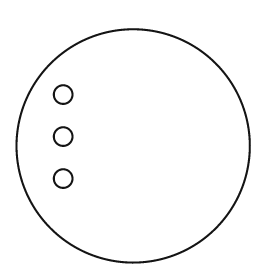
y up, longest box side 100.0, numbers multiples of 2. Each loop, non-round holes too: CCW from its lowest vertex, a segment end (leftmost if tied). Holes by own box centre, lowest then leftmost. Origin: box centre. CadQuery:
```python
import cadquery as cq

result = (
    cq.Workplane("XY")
    .moveTo(0.0, 0.0)
    .circle(50.0)
    .moveTo(-30.0, -14.0)
    .circle(4.0)
    .moveTo(-30.0, 4.0)
    .circle(4.0)
    .moveTo(-30.0, 22.0)
    .circle(4.0)
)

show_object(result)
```